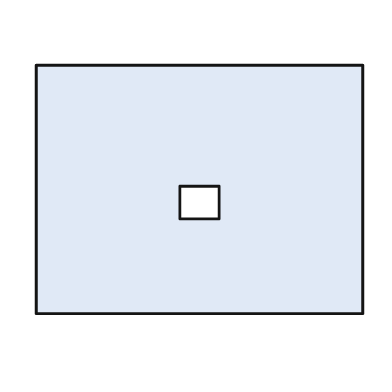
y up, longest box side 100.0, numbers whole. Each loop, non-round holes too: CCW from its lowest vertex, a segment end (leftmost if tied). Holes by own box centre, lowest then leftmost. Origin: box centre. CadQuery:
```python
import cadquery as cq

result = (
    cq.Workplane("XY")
    .moveTo(-50.0, -38.0)
    .lineTo(50.0, -38.0)
    .lineTo(50.0, 38.0)
    .lineTo(-50.0, 38.0)
    .close()
    .moveTo(-6.0, -9.0)
    .lineTo(6.0, -9.0)
    .lineTo(6.0, 1.0)
    .lineTo(-6.0, 1.0)
    .close()
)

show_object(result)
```